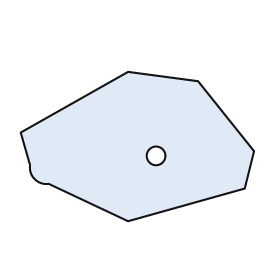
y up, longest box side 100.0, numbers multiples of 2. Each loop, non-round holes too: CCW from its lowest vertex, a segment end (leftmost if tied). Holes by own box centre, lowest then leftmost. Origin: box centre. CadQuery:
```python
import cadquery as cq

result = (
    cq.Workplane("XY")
    .moveTo(-4.0, -32.0)
    .lineTo(46.0, -18.0)
    .lineTo(50.0, -2.0)
    .lineTo(26.0, 28.0)
    .lineTo(-4.0, 32.0)
    .lineTo(-50.0, 6.0)
    .lineTo(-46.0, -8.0)
    .threePointArc((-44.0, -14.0), (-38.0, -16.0))
    .close()
    .moveTo(8.0, -4.0)
    .circle(4.0)
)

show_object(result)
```